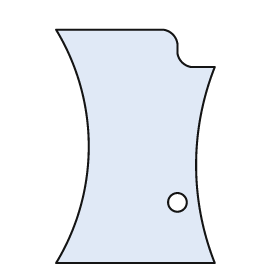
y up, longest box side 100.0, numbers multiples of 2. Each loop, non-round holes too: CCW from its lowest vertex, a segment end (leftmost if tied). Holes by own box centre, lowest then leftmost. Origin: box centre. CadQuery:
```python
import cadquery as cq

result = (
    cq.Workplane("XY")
    .moveTo(-34.0, -50.0)
    .lineTo(34.0, -50.0)
    .threePointArc((26.0, -8.0), (34.0, 34.0))
    .lineTo(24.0, 34.0)
    .threePointArc((20.0, 36.0), (18.0, 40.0))
    .lineTo(18.0, 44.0)
    .threePointArc((16.0, 48.0), (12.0, 50.0))
    .lineTo(-34.0, 50.0)
    .threePointArc((-20.0, 0.0), (-34.0, -50.0))
    .close()
    .moveTo(18.0, -24.0)
    .circle(4.0)
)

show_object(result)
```